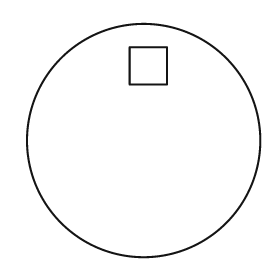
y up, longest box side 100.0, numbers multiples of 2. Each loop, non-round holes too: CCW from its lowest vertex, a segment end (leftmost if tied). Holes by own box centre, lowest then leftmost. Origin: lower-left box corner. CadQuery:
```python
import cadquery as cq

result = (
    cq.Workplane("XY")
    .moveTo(50.0, 50.0)
    .circle(50.0)
    .moveTo(44.0, 74.0)
    .lineTo(60.0, 74.0)
    .lineTo(60.0, 90.0)
    .lineTo(44.0, 90.0)
    .close()
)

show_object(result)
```